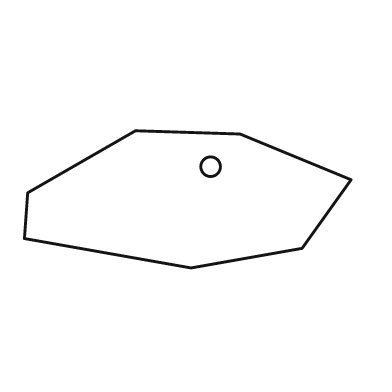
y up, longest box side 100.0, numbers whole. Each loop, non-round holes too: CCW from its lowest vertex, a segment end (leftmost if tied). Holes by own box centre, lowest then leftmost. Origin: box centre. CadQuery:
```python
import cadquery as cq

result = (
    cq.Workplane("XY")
    .moveTo(1.0, -21.0)
    .lineTo(35.0, -15.0)
    .lineTo(50.0, 6.0)
    .lineTo(16.0, 20.0)
    .lineTo(-16.0, 21.0)
    .lineTo(-49.0, 2.0)
    .lineTo(-50.0, -12.0)
    .close()
    .moveTo(7.0, 10.0)
    .circle(3.0)
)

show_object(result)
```